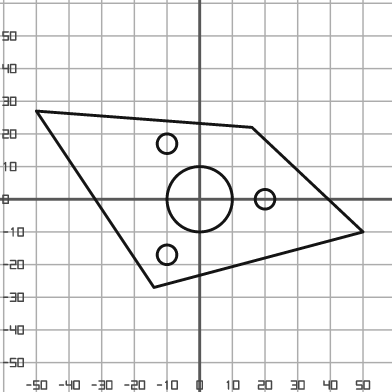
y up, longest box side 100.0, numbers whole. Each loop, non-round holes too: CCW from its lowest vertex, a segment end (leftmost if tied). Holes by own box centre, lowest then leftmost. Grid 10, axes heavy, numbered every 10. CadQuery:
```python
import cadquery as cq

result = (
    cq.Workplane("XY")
    .moveTo(-14.0, -27.0)
    .lineTo(50.0, -10.0)
    .lineTo(16.0, 22.0)
    .lineTo(-50.0, 27.0)
    .close()
    .moveTo(-10.0, -17.0)
    .circle(3.0)
    .moveTo(0.0, 0.0)
    .circle(10.0)
    .moveTo(20.0, 0.0)
    .circle(3.0)
    .moveTo(-10.0, 17.0)
    .circle(3.0)
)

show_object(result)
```